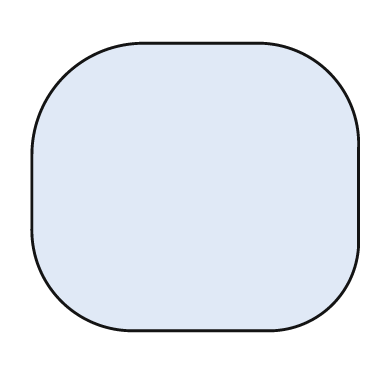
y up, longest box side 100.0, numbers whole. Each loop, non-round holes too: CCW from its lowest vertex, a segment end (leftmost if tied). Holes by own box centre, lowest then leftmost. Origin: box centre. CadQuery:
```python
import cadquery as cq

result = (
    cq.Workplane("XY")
    .moveTo(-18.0, -44.0)
    .lineTo(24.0, -44.0)
    .threePointArc((42.0, -36.0), (50.0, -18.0))
    .lineTo(50.0, 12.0)
    .threePointArc((41.0, 35.0), (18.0, 44.0))
    .lineTo(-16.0, 44.0)
    .threePointArc((-40.0, 34.0), (-50.0, 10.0))
    .lineTo(-50.0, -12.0)
    .threePointArc((-41.0, -35.0), (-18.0, -44.0))
    .close()
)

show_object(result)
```